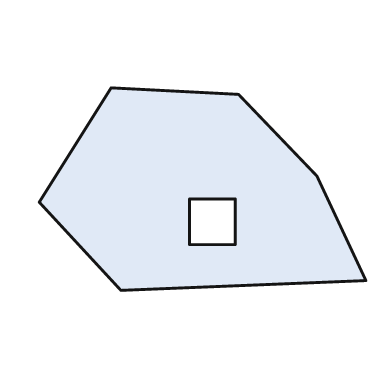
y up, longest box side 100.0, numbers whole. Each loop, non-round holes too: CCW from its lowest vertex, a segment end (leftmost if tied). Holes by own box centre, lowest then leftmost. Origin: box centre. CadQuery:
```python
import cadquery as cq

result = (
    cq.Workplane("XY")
    .moveTo(-25.0, -31.0)
    .lineTo(50.0, -28.0)
    .lineTo(35.0, 4.0)
    .lineTo(11.0, 29.0)
    .lineTo(-28.0, 31.0)
    .lineTo(-50.0, -4.0)
    .close()
    .moveTo(-4.0, -17.0)
    .lineTo(10.0, -17.0)
    .lineTo(10.0, -3.0)
    .lineTo(-4.0, -3.0)
    .close()
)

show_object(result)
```